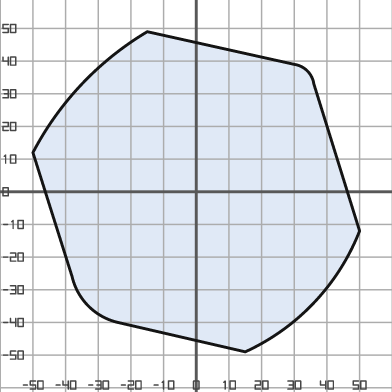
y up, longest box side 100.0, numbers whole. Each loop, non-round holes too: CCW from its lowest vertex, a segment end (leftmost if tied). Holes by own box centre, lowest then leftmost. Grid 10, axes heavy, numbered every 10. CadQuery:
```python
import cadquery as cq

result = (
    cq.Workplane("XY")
    .moveTo(15.0, -49.0)
    .threePointArc((36.0, -34.0), (50.0, -12.0))
    .lineTo(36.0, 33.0)
    .threePointArc((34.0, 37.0), (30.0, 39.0))
    .lineTo(-15.0, 49.0)
    .threePointArc((-35.0, 33.0), (-50.0, 12.0))
    .lineTo(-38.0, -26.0)
    .threePointArc((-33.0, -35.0), (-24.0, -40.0))
    .close()
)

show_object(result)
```